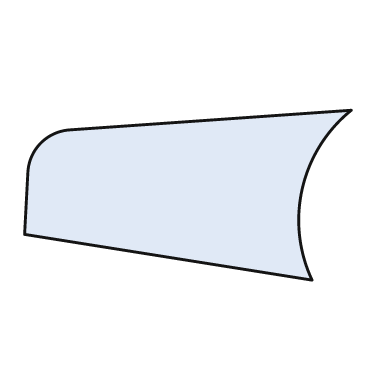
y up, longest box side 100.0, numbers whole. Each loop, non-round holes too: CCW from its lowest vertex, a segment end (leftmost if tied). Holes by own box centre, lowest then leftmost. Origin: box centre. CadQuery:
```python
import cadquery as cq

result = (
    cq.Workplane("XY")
    .moveTo(38.0, -26.0)
    .threePointArc((35.0, 2.0), (50.0, 26.0))
    .lineTo(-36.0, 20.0)
    .threePointArc((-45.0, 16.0), (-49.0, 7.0))
    .lineTo(-50.0, -12.0)
    .close()
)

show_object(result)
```